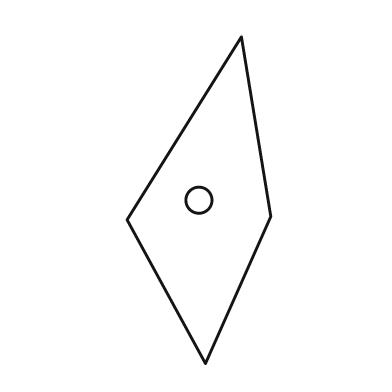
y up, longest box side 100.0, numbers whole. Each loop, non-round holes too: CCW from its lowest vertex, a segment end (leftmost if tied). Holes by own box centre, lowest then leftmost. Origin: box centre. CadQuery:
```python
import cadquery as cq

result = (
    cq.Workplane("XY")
    .moveTo(2.0, -50.0)
    .lineTo(22.0, -5.0)
    .lineTo(13.0, 50.0)
    .lineTo(-22.0, -6.0)
    .close()
    .moveTo(0.0, 0.0)
    .circle(4.0)
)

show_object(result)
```